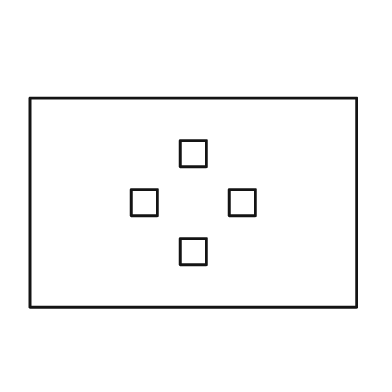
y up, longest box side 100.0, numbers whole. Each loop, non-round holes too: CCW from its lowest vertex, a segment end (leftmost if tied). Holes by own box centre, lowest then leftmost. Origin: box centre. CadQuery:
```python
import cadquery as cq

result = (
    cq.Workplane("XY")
    .moveTo(-50.0, -32.0)
    .lineTo(50.0, -32.0)
    .lineTo(50.0, 32.0)
    .lineTo(-50.0, 32.0)
    .close()
    .moveTo(-4.0, -19.0)
    .lineTo(4.0, -19.0)
    .lineTo(4.0, -11.0)
    .lineTo(-4.0, -11.0)
    .close()
    .moveTo(-19.0, -4.0)
    .lineTo(-11.0, -4.0)
    .lineTo(-11.0, 4.0)
    .lineTo(-19.0, 4.0)
    .close()
    .moveTo(11.0, -4.0)
    .lineTo(19.0, -4.0)
    .lineTo(19.0, 4.0)
    .lineTo(11.0, 4.0)
    .close()
    .moveTo(-4.0, 11.0)
    .lineTo(4.0, 11.0)
    .lineTo(4.0, 19.0)
    .lineTo(-4.0, 19.0)
    .close()
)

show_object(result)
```